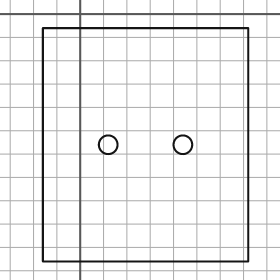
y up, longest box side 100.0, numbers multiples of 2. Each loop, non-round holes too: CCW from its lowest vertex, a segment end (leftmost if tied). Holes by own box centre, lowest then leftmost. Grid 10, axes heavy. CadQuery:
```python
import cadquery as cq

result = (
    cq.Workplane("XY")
    .moveTo(-16.0, -106.0)
    .lineTo(72.0, -106.0)
    .lineTo(72.0, -6.0)
    .lineTo(-16.0, -6.0)
    .close()
    .moveTo(12.0, -56.0)
    .circle(4.0)
    .moveTo(44.0, -56.0)
    .circle(4.0)
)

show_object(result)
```